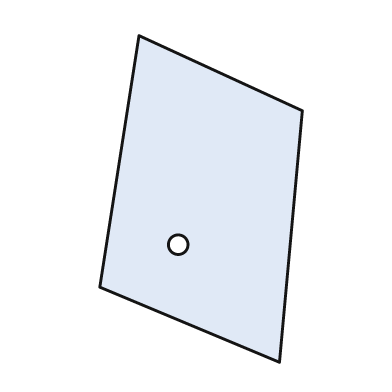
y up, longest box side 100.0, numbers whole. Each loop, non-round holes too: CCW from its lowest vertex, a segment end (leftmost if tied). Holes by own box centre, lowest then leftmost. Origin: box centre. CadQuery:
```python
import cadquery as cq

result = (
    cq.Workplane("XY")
    .moveTo(24.0, -50.0)
    .lineTo(31.0, 27.0)
    .lineTo(-19.0, 50.0)
    .lineTo(-31.0, -27.0)
    .close()
    .moveTo(-7.0, -14.0)
    .circle(3.0)
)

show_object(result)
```